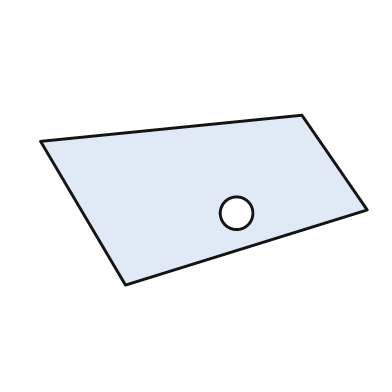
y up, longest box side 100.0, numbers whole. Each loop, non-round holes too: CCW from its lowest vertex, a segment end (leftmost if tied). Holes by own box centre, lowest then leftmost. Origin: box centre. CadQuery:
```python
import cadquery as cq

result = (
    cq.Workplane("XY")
    .moveTo(-24.0, -26.0)
    .lineTo(50.0, -3.0)
    .lineTo(30.0, 26.0)
    .lineTo(-50.0, 18.0)
    .close()
    .moveTo(10.0, -4.0)
    .circle(5.0)
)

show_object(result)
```